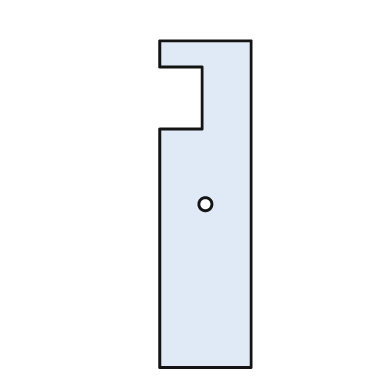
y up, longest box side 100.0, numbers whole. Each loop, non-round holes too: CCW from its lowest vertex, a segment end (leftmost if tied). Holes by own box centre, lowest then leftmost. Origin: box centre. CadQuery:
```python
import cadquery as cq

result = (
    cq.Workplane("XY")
    .moveTo(-14.0, -50.0)
    .lineTo(14.0, -50.0)
    .lineTo(14.0, 50.0)
    .lineTo(-14.0, 50.0)
    .lineTo(-14.0, 42.0)
    .lineTo(-1.0, 42.0)
    .lineTo(-1.0, 23.0)
    .lineTo(-14.0, 23.0)
    .close()
    .moveTo(0.0, 0.0)
    .circle(2.0)
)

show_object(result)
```